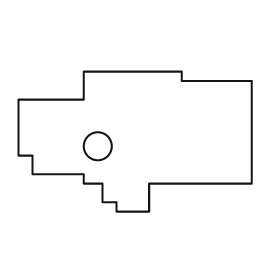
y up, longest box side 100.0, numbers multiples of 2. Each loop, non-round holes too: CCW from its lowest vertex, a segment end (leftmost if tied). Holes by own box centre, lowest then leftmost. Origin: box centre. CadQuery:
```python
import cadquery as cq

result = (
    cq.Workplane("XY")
    .moveTo(-8.0, -30.0)
    .lineTo(6.0, -30.0)
    .lineTo(6.0, -18.0)
    .lineTo(50.0, -18.0)
    .lineTo(50.0, 26.0)
    .lineTo(20.0, 26.0)
    .lineTo(20.0, 30.0)
    .lineTo(-22.0, 30.0)
    .lineTo(-22.0, 18.0)
    .lineTo(-50.0, 18.0)
    .lineTo(-50.0, -6.0)
    .lineTo(-44.0, -6.0)
    .lineTo(-44.0, -14.0)
    .lineTo(-22.0, -14.0)
    .lineTo(-22.0, -18.0)
    .lineTo(-14.0, -18.0)
    .lineTo(-14.0, -26.0)
    .lineTo(-8.0, -26.0)
    .close()
    .moveTo(-16.0, -2.0)
    .circle(6.0)
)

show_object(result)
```